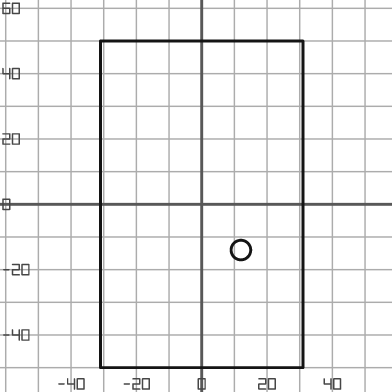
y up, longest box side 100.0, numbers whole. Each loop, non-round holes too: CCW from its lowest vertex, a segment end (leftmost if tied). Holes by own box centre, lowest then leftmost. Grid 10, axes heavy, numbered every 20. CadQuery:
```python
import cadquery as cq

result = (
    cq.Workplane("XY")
    .moveTo(-31.0, -50.0)
    .lineTo(31.0, -50.0)
    .lineTo(31.0, 50.0)
    .lineTo(-31.0, 50.0)
    .close()
    .moveTo(12.0, -14.0)
    .circle(3.0)
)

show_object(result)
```